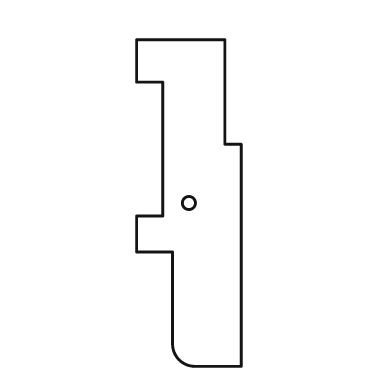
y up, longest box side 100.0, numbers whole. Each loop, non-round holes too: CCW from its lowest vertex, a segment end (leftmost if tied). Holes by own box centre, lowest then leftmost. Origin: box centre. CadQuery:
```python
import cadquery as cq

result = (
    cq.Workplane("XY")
    .moveTo(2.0, -50.0)
    .lineTo(16.0, -50.0)
    .lineTo(16.0, 18.0)
    .lineTo(11.0, 18.0)
    .lineTo(11.0, 50.0)
    .lineTo(-16.0, 50.0)
    .lineTo(-16.0, 37.0)
    .lineTo(-8.0, 37.0)
    .lineTo(-8.0, -4.0)
    .lineTo(-16.0, -4.0)
    .lineTo(-16.0, -15.0)
    .lineTo(-5.0, -15.0)
    .lineTo(-5.0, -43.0)
    .threePointArc((-3.0, -48.0), (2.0, -50.0))
    .close()
    .moveTo(0.0, 0.0)
    .circle(2.0)
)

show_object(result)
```